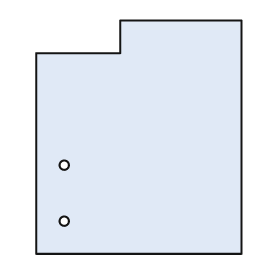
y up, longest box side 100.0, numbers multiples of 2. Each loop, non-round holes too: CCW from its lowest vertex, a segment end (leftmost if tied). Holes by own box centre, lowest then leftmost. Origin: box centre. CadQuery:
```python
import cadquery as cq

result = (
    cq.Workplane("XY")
    .moveTo(-44.0, -50.0)
    .lineTo(44.0, -50.0)
    .lineTo(44.0, 50.0)
    .lineTo(-8.0, 50.0)
    .lineTo(-8.0, 36.0)
    .lineTo(-44.0, 36.0)
    .close()
    .moveTo(-32.0, -36.0)
    .circle(2.0)
    .moveTo(-32.0, -12.0)
    .circle(2.0)
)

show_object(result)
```